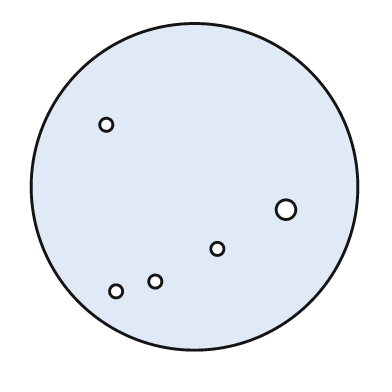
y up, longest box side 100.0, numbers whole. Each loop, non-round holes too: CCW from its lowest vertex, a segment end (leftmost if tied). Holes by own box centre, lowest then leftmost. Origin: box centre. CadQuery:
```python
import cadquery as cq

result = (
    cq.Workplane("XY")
    .moveTo(0.0, 0.0)
    .circle(50.0)
    .moveTo(-24.0, -32.0)
    .circle(2.0)
    .moveTo(-12.0, -29.0)
    .circle(2.0)
    .moveTo(7.0, -19.0)
    .circle(2.0)
    .moveTo(28.0, -7.0)
    .circle(3.0)
    .moveTo(-27.0, 19.0)
    .circle(2.0)
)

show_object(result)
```